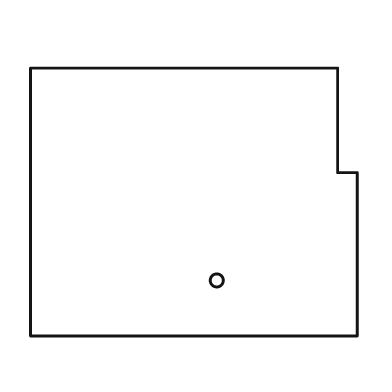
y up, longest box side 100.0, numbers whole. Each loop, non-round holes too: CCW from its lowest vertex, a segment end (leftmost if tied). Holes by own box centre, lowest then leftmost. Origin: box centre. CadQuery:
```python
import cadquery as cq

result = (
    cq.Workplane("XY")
    .moveTo(-50.0, -41.0)
    .lineTo(50.0, -41.0)
    .lineTo(50.0, 9.0)
    .lineTo(44.0, 9.0)
    .lineTo(44.0, 41.0)
    .lineTo(-50.0, 41.0)
    .close()
    .moveTo(7.0, -24.0)
    .circle(2.0)
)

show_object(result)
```